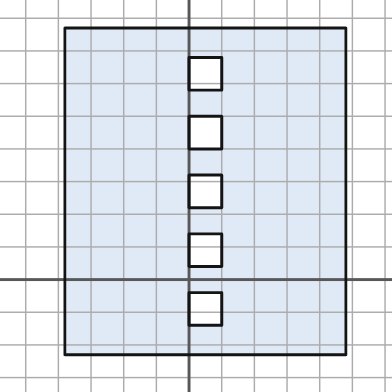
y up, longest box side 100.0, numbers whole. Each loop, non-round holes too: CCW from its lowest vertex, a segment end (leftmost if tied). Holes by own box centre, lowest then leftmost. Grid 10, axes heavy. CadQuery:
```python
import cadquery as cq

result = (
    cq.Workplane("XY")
    .moveTo(-38.0, -23.0)
    .lineTo(48.0, -23.0)
    .lineTo(48.0, 77.0)
    .lineTo(-38.0, 77.0)
    .close()
    .moveTo(0.0, -14.0)
    .lineTo(10.0, -14.0)
    .lineTo(10.0, -4.0)
    .lineTo(0.0, -4.0)
    .close()
    .moveTo(0.0, 4.0)
    .lineTo(10.0, 4.0)
    .lineTo(10.0, 14.0)
    .lineTo(0.0, 14.0)
    .close()
    .moveTo(0.0, 22.0)
    .lineTo(10.0, 22.0)
    .lineTo(10.0, 32.0)
    .lineTo(0.0, 32.0)
    .close()
    .moveTo(0.0, 40.0)
    .lineTo(10.0, 40.0)
    .lineTo(10.0, 50.0)
    .lineTo(0.0, 50.0)
    .close()
    .moveTo(0.0, 58.0)
    .lineTo(10.0, 58.0)
    .lineTo(10.0, 68.0)
    .lineTo(0.0, 68.0)
    .close()
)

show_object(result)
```